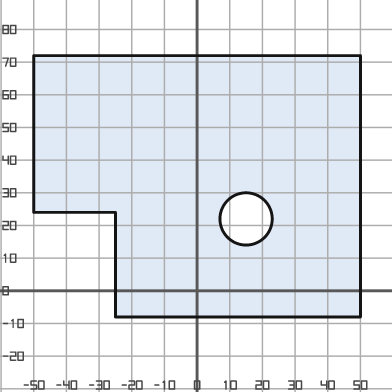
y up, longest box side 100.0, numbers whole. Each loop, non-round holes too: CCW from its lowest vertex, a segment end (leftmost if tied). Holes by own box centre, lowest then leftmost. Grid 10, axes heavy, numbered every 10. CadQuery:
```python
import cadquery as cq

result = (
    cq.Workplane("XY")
    .moveTo(-25.0, -8.0)
    .lineTo(50.0, -8.0)
    .lineTo(50.0, 72.0)
    .lineTo(-50.0, 72.0)
    .lineTo(-50.0, 24.0)
    .lineTo(-25.0, 24.0)
    .close()
    .moveTo(15.0, 22.0)
    .circle(8.0)
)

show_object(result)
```